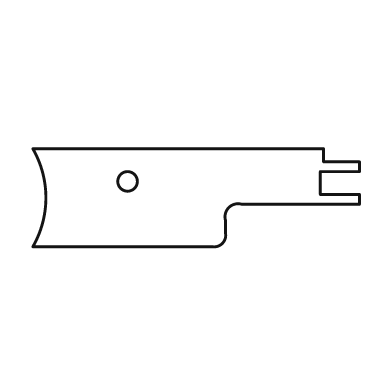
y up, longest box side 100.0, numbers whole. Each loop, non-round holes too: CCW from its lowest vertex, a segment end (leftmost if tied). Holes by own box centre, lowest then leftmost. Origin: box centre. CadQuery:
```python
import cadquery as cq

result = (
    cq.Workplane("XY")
    .moveTo(-50.0, -15.0)
    .lineTo(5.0, -15.0)
    .threePointArc((8.0, -14.0), (9.0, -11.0))
    .lineTo(9.0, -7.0)
    .threePointArc((10.0, -3.0), (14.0, -2.0))
    .lineTo(50.0, -2.0)
    .lineTo(50.0, 1.0)
    .lineTo(38.0, 1.0)
    .lineTo(38.0, 8.0)
    .lineTo(50.0, 8.0)
    .lineTo(50.0, 11.0)
    .lineTo(39.0, 11.0)
    .lineTo(39.0, 15.0)
    .lineTo(-50.0, 15.0)
    .threePointArc((-46.0, 0.0), (-50.0, -15.0))
    .close()
    .moveTo(-21.0, 5.0)
    .circle(3.0)
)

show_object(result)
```